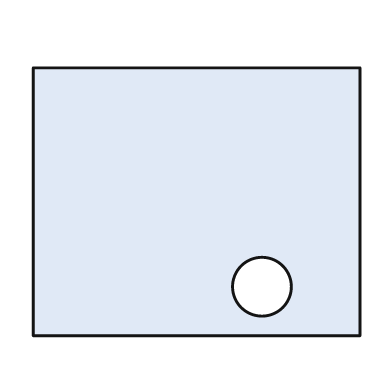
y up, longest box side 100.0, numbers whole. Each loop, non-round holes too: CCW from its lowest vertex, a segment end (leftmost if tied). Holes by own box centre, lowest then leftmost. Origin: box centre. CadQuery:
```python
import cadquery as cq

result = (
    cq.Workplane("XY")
    .moveTo(-50.0, -41.0)
    .lineTo(50.0, -41.0)
    .lineTo(50.0, 41.0)
    .lineTo(-50.0, 41.0)
    .close()
    .moveTo(20.0, -26.0)
    .circle(9.0)
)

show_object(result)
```